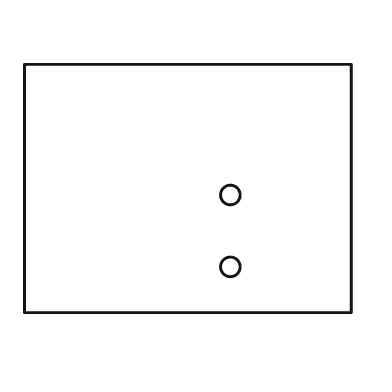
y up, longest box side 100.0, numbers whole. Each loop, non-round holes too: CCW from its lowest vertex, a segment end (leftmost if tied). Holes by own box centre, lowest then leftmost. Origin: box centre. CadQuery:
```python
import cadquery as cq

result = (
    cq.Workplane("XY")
    .moveTo(-50.0, -38.0)
    .lineTo(50.0, -38.0)
    .lineTo(50.0, 38.0)
    .lineTo(-50.0, 38.0)
    .close()
    .moveTo(13.0, -24.0)
    .circle(3.0)
    .moveTo(13.0, -2.0)
    .circle(3.0)
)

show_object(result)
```